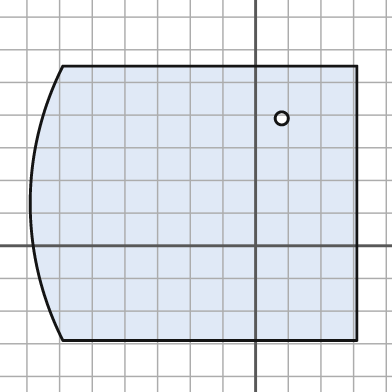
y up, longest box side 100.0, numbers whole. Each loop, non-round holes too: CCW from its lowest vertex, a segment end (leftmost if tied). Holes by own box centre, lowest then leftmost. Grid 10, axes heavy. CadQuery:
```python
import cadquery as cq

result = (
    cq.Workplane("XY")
    .moveTo(-59.0, -29.0)
    .lineTo(31.0, -29.0)
    .lineTo(31.0, 55.0)
    .lineTo(-59.0, 55.0)
    .threePointArc((-69.0, 13.0), (-59.0, -29.0))
    .close()
    .moveTo(8.0, 39.0)
    .circle(2.0)
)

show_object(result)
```